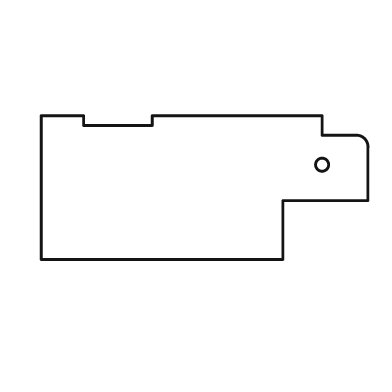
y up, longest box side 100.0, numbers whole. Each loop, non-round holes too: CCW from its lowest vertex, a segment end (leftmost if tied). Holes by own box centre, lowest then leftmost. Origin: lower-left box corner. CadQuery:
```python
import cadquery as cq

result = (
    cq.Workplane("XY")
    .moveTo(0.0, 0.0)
    .lineTo(74.0, 0.0)
    .lineTo(74.0, 18.0)
    .lineTo(100.0, 18.0)
    .lineTo(100.0, 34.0)
    .threePointArc((99.0, 37.0), (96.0, 38.0))
    .lineTo(86.0, 38.0)
    .lineTo(86.0, 44.0)
    .lineTo(34.0, 44.0)
    .lineTo(34.0, 41.0)
    .lineTo(13.0, 41.0)
    .lineTo(13.0, 44.0)
    .lineTo(0.0, 44.0)
    .close()
    .moveTo(86.0, 29.0)
    .circle(2.0)
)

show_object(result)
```